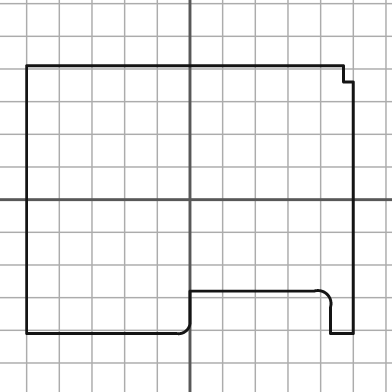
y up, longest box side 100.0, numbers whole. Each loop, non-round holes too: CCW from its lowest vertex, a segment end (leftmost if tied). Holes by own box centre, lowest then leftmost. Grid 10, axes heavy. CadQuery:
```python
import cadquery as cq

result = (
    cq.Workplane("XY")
    .moveTo(-50.0, -41.0)
    .lineTo(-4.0, -41.0)
    .threePointArc((-1.0, -40.0), (0.0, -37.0))
    .lineTo(0.0, -28.0)
    .lineTo(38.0, -28.0)
    .threePointArc((42.0, -29.0), (43.0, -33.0))
    .lineTo(43.0, -41.0)
    .lineTo(50.0, -41.0)
    .lineTo(50.0, 36.0)
    .lineTo(47.0, 36.0)
    .lineTo(47.0, 41.0)
    .lineTo(-50.0, 41.0)
    .close()
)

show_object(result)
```